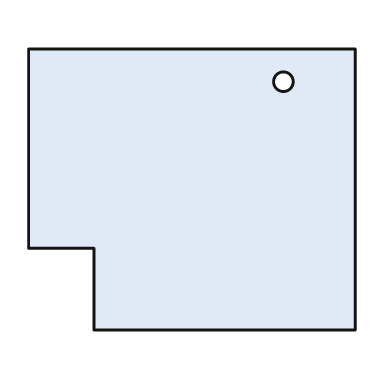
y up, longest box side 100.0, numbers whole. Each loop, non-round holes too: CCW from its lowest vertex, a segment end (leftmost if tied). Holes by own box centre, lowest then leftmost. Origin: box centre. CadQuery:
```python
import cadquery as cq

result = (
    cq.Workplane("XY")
    .moveTo(-30.0, -43.0)
    .lineTo(50.0, -43.0)
    .lineTo(50.0, 43.0)
    .lineTo(-50.0, 43.0)
    .lineTo(-50.0, -18.0)
    .lineTo(-30.0, -18.0)
    .close()
    .moveTo(28.0, 33.0)
    .circle(3.0)
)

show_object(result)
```